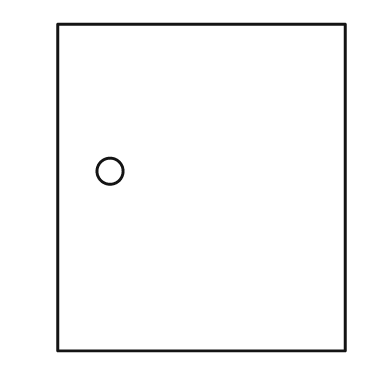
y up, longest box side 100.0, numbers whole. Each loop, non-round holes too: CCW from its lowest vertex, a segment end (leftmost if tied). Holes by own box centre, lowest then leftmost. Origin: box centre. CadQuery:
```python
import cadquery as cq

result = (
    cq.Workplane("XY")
    .moveTo(-44.0, -50.0)
    .lineTo(44.0, -50.0)
    .lineTo(44.0, 50.0)
    .lineTo(-44.0, 50.0)
    .close()
    .moveTo(-28.0, 5.0)
    .circle(4.0)
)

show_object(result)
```